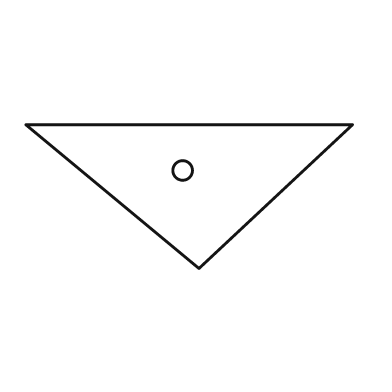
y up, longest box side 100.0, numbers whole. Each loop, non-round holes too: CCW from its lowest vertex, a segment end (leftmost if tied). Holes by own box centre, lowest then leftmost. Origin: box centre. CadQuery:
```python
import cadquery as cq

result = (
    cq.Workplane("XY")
    .moveTo(3.0, -22.0)
    .lineTo(50.0, 22.0)
    .lineTo(-50.0, 22.0)
    .close()
    .moveTo(-2.0, 8.0)
    .circle(3.0)
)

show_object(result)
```